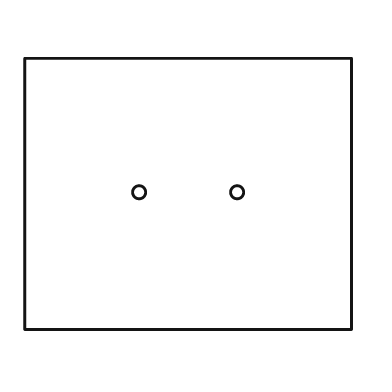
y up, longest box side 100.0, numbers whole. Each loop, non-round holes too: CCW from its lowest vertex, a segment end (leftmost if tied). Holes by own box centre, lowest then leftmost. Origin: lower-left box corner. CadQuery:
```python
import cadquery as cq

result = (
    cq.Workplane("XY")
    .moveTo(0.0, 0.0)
    .lineTo(100.0, 0.0)
    .lineTo(100.0, 83.0)
    .lineTo(0.0, 83.0)
    .close()
    .moveTo(35.0, 42.0)
    .circle(2.0)
    .moveTo(65.0, 42.0)
    .circle(2.0)
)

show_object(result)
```